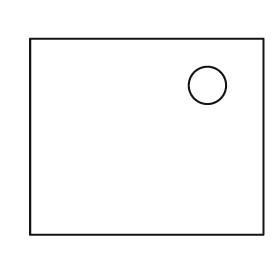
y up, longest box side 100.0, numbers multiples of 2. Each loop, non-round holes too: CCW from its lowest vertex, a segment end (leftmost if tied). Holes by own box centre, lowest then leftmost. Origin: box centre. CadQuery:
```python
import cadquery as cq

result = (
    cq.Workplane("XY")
    .moveTo(-50.0, -42.0)
    .lineTo(50.0, -42.0)
    .lineTo(50.0, 42.0)
    .lineTo(-50.0, 42.0)
    .close()
    .moveTo(26.0, 22.0)
    .circle(8.0)
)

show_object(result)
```